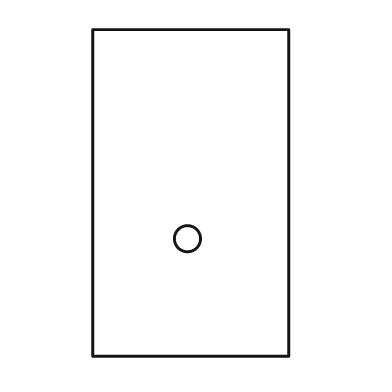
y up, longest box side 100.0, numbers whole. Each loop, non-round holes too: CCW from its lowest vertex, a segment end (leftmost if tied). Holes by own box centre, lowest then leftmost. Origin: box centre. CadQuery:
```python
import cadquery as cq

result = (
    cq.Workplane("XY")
    .moveTo(-30.0, -50.0)
    .lineTo(30.0, -50.0)
    .lineTo(30.0, 50.0)
    .lineTo(-30.0, 50.0)
    .close()
    .moveTo(-1.0, -14.0)
    .circle(4.0)
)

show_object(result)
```